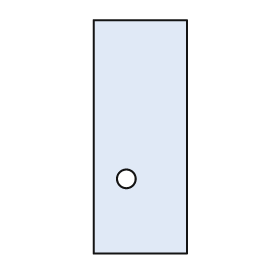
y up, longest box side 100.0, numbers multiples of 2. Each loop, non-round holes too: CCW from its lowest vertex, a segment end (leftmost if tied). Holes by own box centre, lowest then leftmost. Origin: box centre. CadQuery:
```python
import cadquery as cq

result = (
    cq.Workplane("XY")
    .moveTo(-20.0, -50.0)
    .lineTo(20.0, -50.0)
    .lineTo(20.0, 50.0)
    .lineTo(-20.0, 50.0)
    .close()
    .moveTo(-6.0, -18.0)
    .circle(4.0)
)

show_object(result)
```